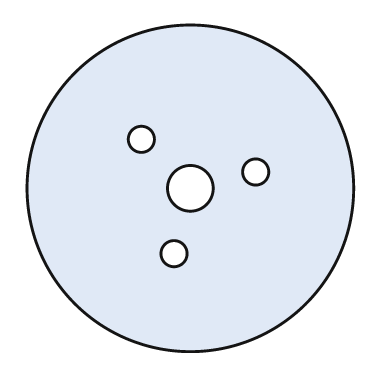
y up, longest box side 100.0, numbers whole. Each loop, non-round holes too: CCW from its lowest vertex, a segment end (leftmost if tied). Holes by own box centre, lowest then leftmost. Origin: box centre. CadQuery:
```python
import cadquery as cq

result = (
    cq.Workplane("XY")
    .moveTo(0.0, 0.0)
    .circle(50.0)
    .moveTo(-5.0, -20.0)
    .circle(4.0)
    .moveTo(0.0, 0.0)
    .circle(7.0)
    .moveTo(20.0, 5.0)
    .circle(4.0)
    .moveTo(-15.0, 15.0)
    .circle(4.0)
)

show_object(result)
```